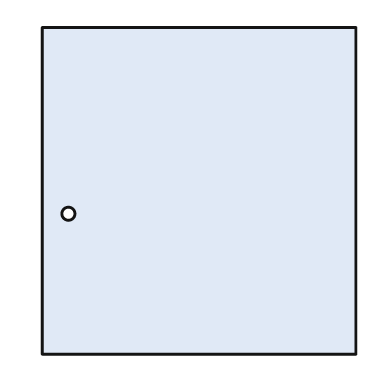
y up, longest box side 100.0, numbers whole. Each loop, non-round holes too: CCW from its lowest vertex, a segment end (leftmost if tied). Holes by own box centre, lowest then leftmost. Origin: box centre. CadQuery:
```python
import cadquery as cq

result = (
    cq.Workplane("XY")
    .moveTo(-48.0, -50.0)
    .lineTo(48.0, -50.0)
    .lineTo(48.0, 50.0)
    .lineTo(-48.0, 50.0)
    .close()
    .moveTo(-40.0, -7.0)
    .circle(2.0)
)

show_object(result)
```